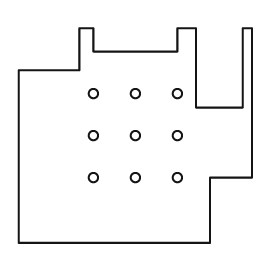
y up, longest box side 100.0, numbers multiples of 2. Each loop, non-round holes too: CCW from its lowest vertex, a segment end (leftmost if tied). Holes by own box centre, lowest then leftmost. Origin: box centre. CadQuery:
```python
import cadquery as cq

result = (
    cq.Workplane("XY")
    .moveTo(-50.0, -46.0)
    .lineTo(32.0, -46.0)
    .lineTo(32.0, -18.0)
    .lineTo(50.0, -18.0)
    .lineTo(50.0, 46.0)
    .lineTo(46.0, 46.0)
    .lineTo(46.0, 12.0)
    .lineTo(26.0, 12.0)
    .lineTo(26.0, 46.0)
    .lineTo(18.0, 46.0)
    .lineTo(18.0, 36.0)
    .lineTo(-18.0, 36.0)
    .lineTo(-18.0, 46.0)
    .lineTo(-24.0, 46.0)
    .lineTo(-24.0, 28.0)
    .lineTo(-50.0, 28.0)
    .close()
    .moveTo(-18.0, -18.0)
    .circle(2.0)
    .moveTo(0.0, -18.0)
    .circle(2.0)
    .moveTo(18.0, -18.0)
    .circle(2.0)
    .moveTo(-18.0, 0.0)
    .circle(2.0)
    .moveTo(0.0, 0.0)
    .circle(2.0)
    .moveTo(18.0, 0.0)
    .circle(2.0)
    .moveTo(-18.0, 18.0)
    .circle(2.0)
    .moveTo(0.0, 18.0)
    .circle(2.0)
    .moveTo(18.0, 18.0)
    .circle(2.0)
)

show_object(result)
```